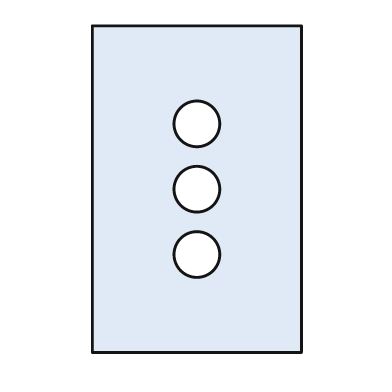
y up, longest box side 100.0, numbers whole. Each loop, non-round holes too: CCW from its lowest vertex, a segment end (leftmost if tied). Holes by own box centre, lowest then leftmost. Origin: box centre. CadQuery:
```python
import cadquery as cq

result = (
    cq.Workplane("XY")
    .moveTo(-32.0, -50.0)
    .lineTo(32.0, -50.0)
    .lineTo(32.0, 50.0)
    .lineTo(-32.0, 50.0)
    .close()
    .moveTo(0.0, -20.0)
    .circle(7.0)
    .moveTo(0.0, 0.0)
    .circle(7.0)
    .moveTo(0.0, 20.0)
    .circle(7.0)
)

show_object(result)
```